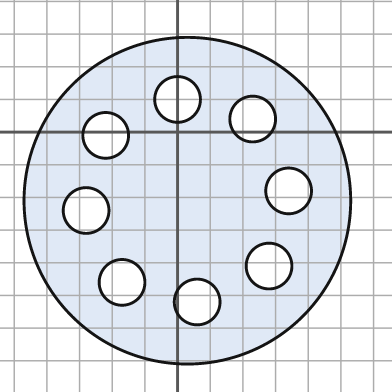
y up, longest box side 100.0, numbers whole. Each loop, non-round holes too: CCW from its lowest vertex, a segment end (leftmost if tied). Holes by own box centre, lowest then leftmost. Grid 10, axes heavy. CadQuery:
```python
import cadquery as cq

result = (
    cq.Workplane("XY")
    .moveTo(3.0, -21.0)
    .circle(50.0)
    .moveTo(6.0, -52.0)
    .circle(7.0)
    .moveTo(-17.0, -46.0)
    .circle(7.0)
    .moveTo(28.0, -41.0)
    .circle(7.0)
    .moveTo(-28.0, -24.0)
    .circle(7.0)
    .moveTo(34.0, -18.0)
    .circle(7.0)
    .moveTo(-22.0, -1.0)
    .circle(7.0)
    .moveTo(23.0, 4.0)
    .circle(7.0)
    .moveTo(0.0, 10.0)
    .circle(7.0)
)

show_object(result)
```